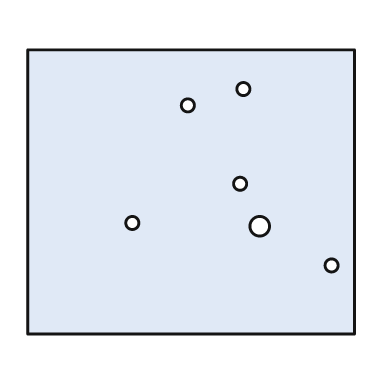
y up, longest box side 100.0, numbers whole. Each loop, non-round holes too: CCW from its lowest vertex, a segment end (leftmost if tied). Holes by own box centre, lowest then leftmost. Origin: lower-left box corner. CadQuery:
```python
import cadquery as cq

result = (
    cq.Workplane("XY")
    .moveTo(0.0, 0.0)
    .lineTo(100.0, 0.0)
    .lineTo(100.0, 87.0)
    .lineTo(0.0, 87.0)
    .close()
    .moveTo(93.0, 21.0)
    .circle(2.0)
    .moveTo(71.0, 33.0)
    .circle(3.0)
    .moveTo(32.0, 34.0)
    .circle(2.0)
    .moveTo(65.0, 46.0)
    .circle(2.0)
    .moveTo(49.0, 70.0)
    .circle(2.0)
    .moveTo(66.0, 75.0)
    .circle(2.0)
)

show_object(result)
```